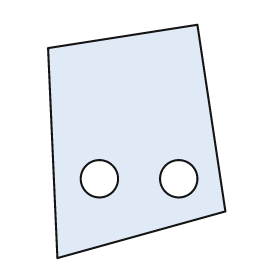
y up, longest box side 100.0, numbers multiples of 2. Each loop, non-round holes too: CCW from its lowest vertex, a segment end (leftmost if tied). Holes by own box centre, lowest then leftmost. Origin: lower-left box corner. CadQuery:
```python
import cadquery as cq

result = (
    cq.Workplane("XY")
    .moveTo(4.0, 0.0)
    .lineTo(76.0, 20.0)
    .lineTo(64.0, 100.0)
    .lineTo(0.0, 90.0)
    .close()
    .moveTo(22.0, 34.0)
    .circle(8.0)
    .moveTo(56.0, 34.0)
    .circle(8.0)
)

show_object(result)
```